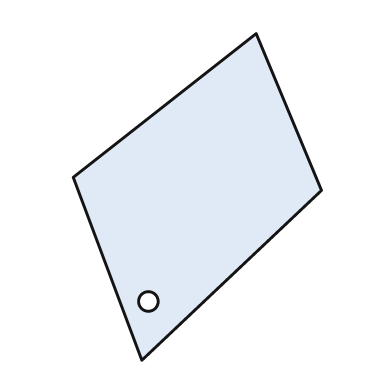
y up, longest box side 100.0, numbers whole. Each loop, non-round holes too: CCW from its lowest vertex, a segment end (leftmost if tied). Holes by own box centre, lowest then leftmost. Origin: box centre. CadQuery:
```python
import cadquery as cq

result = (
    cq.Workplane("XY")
    .moveTo(-17.0, -50.0)
    .lineTo(38.0, 2.0)
    .lineTo(18.0, 50.0)
    .lineTo(-38.0, 6.0)
    .close()
    .moveTo(-15.0, -32.0)
    .circle(3.0)
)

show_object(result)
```